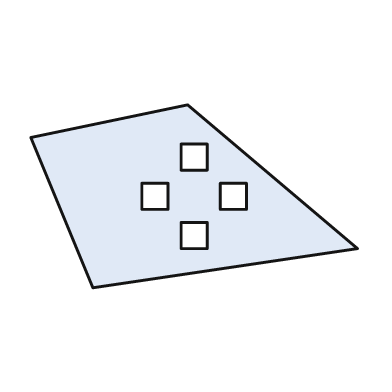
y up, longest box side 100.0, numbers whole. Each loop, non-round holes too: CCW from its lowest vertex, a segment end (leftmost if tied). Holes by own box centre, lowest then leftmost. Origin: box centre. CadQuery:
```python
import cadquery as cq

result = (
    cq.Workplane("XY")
    .moveTo(-31.0, -28.0)
    .lineTo(50.0, -16.0)
    .lineTo(-2.0, 28.0)
    .lineTo(-50.0, 18.0)
    .close()
    .moveTo(-4.0, -16.0)
    .lineTo(4.0, -16.0)
    .lineTo(4.0, -8.0)
    .lineTo(-4.0, -8.0)
    .close()
    .moveTo(-16.0, -4.0)
    .lineTo(-8.0, -4.0)
    .lineTo(-8.0, 4.0)
    .lineTo(-16.0, 4.0)
    .close()
    .moveTo(8.0, -4.0)
    .lineTo(16.0, -4.0)
    .lineTo(16.0, 4.0)
    .lineTo(8.0, 4.0)
    .close()
    .moveTo(-4.0, 8.0)
    .lineTo(4.0, 8.0)
    .lineTo(4.0, 16.0)
    .lineTo(-4.0, 16.0)
    .close()
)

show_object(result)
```